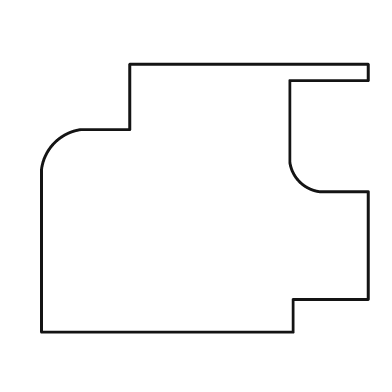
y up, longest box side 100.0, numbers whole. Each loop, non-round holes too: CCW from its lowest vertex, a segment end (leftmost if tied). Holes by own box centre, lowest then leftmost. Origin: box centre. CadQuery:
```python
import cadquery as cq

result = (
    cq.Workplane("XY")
    .moveTo(-50.0, -41.0)
    .lineTo(27.0, -41.0)
    .lineTo(27.0, -31.0)
    .lineTo(50.0, -31.0)
    .lineTo(50.0, 2.0)
    .lineTo(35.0, 2.0)
    .threePointArc((29.0, 5.0), (26.0, 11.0))
    .lineTo(26.0, 36.0)
    .lineTo(50.0, 36.0)
    .lineTo(50.0, 41.0)
    .lineTo(-23.0, 41.0)
    .lineTo(-23.0, 21.0)
    .lineTo(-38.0, 21.0)
    .threePointArc((-46.0, 17.0), (-50.0, 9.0))
    .close()
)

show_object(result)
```